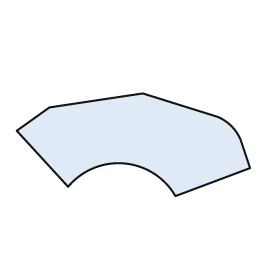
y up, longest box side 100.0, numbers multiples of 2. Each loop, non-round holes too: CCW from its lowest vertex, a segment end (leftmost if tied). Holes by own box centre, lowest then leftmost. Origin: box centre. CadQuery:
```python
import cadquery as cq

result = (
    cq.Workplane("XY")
    .moveTo(18.0, -22.0)
    .lineTo(50.0, -10.0)
    .lineTo(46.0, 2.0)
    .threePointArc((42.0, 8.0), (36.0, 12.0))
    .lineTo(4.0, 22.0)
    .lineTo(-36.0, 16.0)
    .lineTo(-50.0, 6.0)
    .lineTo(-28.0, -18.0)
    .threePointArc((-4.0, -8.0), (18.0, -22.0))
    .close()
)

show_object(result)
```